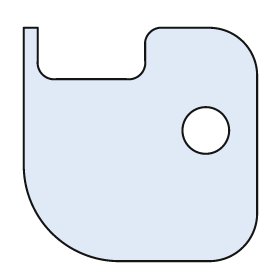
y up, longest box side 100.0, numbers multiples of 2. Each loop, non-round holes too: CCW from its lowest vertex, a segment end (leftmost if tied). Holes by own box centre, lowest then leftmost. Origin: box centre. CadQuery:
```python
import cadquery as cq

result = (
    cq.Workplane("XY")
    .moveTo(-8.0, -50.0)
    .lineTo(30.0, -50.0)
    .threePointArc((44.0, -44.0), (50.0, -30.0))
    .lineTo(50.0, 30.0)
    .threePointArc((44.0, 44.0), (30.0, 50.0))
    .lineTo(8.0, 50.0)
    .threePointArc((4.0, 48.0), (2.0, 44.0))
    .lineTo(2.0, 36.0)
    .threePointArc((0.0, 30.0), (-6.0, 28.0))
    .lineTo(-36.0, 28.0)
    .threePointArc((-42.0, 30.0), (-44.0, 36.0))
    .lineTo(-44.0, 50.0)
    .lineTo(-50.0, 50.0)
    .lineTo(-50.0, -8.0)
    .threePointArc((-38.0, -38.0), (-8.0, -50.0))
    .close()
    .moveTo(28.0, 6.0)
    .circle(10.0)
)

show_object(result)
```